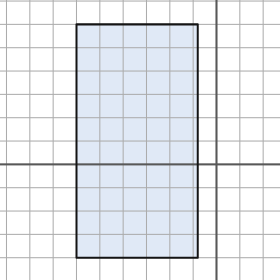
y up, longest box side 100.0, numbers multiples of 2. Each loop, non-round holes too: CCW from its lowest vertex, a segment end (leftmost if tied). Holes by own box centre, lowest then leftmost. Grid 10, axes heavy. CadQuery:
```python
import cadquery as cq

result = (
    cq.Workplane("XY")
    .moveTo(-60.0, -40.0)
    .lineTo(-8.0, -40.0)
    .lineTo(-8.0, 60.0)
    .lineTo(-60.0, 60.0)
    .close()
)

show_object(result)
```